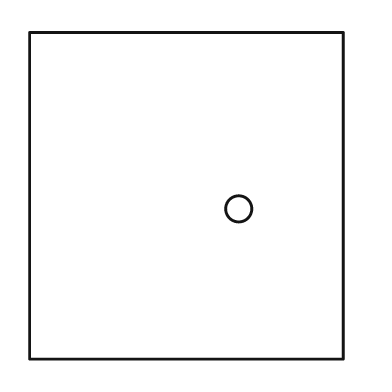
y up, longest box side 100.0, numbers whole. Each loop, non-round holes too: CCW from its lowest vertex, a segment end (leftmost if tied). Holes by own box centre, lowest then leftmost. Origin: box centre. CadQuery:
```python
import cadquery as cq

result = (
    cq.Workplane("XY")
    .moveTo(-48.0, -50.0)
    .lineTo(48.0, -50.0)
    .lineTo(48.0, 50.0)
    .lineTo(-48.0, 50.0)
    .close()
    .moveTo(16.0, -4.0)
    .circle(4.0)
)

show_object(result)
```